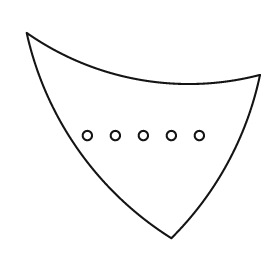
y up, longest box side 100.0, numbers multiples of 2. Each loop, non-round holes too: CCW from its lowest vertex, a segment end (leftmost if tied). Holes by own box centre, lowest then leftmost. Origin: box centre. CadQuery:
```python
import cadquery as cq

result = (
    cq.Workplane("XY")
    .moveTo(12.0, -44.0)
    .threePointArc((36.0, -12.0), (50.0, 26.0))
    .threePointArc((-2.0, 24.0), (-50.0, 44.0))
    .threePointArc((-28.0, -6.0), (12.0, -44.0))
    .close()
    .moveTo(-24.0, 0.0)
    .circle(2.0)
    .moveTo(-12.0, 0.0)
    .circle(2.0)
    .moveTo(0.0, 0.0)
    .circle(2.0)
    .moveTo(12.0, 0.0)
    .circle(2.0)
    .moveTo(24.0, 0.0)
    .circle(2.0)
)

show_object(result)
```